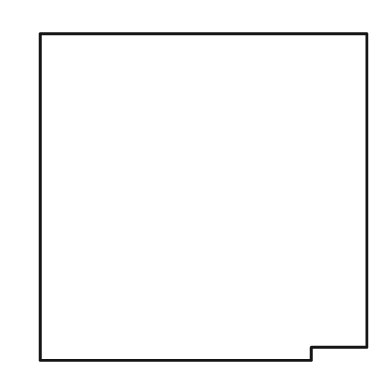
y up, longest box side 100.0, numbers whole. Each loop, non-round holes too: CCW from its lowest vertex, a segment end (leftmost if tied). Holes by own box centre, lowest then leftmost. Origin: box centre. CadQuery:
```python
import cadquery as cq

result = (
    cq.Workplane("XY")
    .moveTo(-50.0, -50.0)
    .lineTo(33.0, -50.0)
    .lineTo(33.0, -46.0)
    .lineTo(50.0, -46.0)
    .lineTo(50.0, 50.0)
    .lineTo(-50.0, 50.0)
    .close()
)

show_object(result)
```